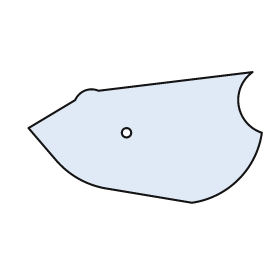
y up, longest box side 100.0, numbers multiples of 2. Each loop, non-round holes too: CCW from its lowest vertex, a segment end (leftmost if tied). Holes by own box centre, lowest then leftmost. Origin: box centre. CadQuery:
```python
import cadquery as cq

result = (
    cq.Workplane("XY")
    .moveTo(20.0, -28.0)
    .threePointArc((40.0, -18.0), (50.0, 2.0))
    .threePointArc((40.0, 14.0), (46.0, 28.0))
    .lineTo(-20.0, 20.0)
    .threePointArc((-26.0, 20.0), (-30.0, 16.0))
    .lineTo(-50.0, 4.0)
    .lineTo(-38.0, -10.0)
    .threePointArc((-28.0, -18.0), (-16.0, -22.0))
    .close()
    .moveTo(-8.0, 2.0)
    .circle(2.0)
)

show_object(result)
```